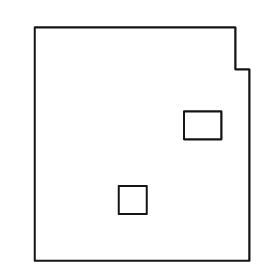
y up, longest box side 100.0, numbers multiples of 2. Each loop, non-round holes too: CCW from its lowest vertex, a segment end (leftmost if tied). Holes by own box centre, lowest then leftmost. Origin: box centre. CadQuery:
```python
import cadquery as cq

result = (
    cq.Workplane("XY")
    .moveTo(-46.0, -50.0)
    .lineTo(46.0, -50.0)
    .lineTo(46.0, 32.0)
    .lineTo(40.0, 32.0)
    .lineTo(40.0, 50.0)
    .lineTo(-46.0, 50.0)
    .close()
    .moveTo(-10.0, -30.0)
    .lineTo(2.0, -30.0)
    .lineTo(2.0, -18.0)
    .lineTo(-10.0, -18.0)
    .close()
    .moveTo(18.0, 2.0)
    .lineTo(34.0, 2.0)
    .lineTo(34.0, 14.0)
    .lineTo(18.0, 14.0)
    .close()
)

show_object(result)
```